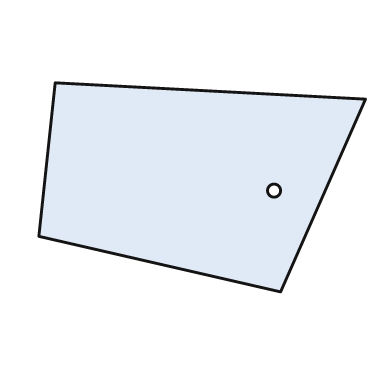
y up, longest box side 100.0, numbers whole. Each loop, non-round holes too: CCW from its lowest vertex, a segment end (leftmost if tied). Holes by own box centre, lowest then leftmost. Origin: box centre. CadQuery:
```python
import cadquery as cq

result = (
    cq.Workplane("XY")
    .moveTo(24.0, -32.0)
    .lineTo(50.0, 27.0)
    .lineTo(-45.0, 32.0)
    .lineTo(-50.0, -15.0)
    .close()
    .moveTo(22.0, -1.0)
    .circle(2.0)
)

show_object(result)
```